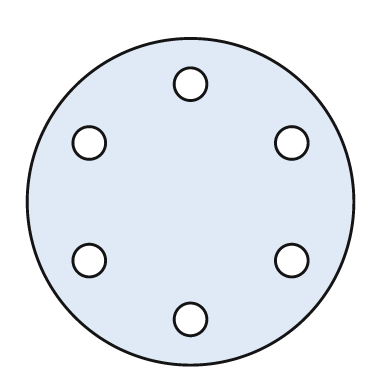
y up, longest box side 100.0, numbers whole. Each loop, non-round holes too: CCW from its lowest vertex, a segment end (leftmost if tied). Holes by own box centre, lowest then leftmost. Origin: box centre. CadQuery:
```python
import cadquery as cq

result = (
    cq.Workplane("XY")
    .moveTo(0.0, 0.0)
    .circle(50.0)
    .moveTo(0.0, -36.0)
    .circle(5.0)
    .moveTo(-31.0, -18.0)
    .circle(5.0)
    .moveTo(31.0, -18.0)
    .circle(5.0)
    .moveTo(-31.0, 18.0)
    .circle(5.0)
    .moveTo(31.0, 18.0)
    .circle(5.0)
    .moveTo(0.0, 36.0)
    .circle(5.0)
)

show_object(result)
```